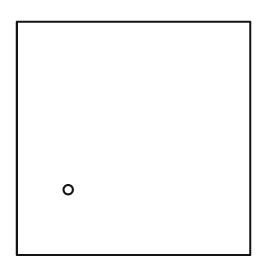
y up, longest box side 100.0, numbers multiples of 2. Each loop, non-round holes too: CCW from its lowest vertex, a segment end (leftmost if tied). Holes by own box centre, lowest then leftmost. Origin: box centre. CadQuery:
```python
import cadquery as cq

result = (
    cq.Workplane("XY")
    .moveTo(-50.0, -50.0)
    .lineTo(50.0, -50.0)
    .lineTo(50.0, 50.0)
    .lineTo(-50.0, 50.0)
    .close()
    .moveTo(-28.0, -22.0)
    .circle(2.0)
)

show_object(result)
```